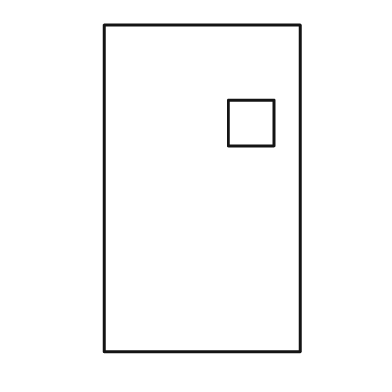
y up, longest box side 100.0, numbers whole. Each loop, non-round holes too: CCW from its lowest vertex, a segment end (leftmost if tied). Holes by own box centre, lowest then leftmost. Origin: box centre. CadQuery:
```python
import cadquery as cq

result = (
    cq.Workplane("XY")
    .moveTo(-30.0, -50.0)
    .lineTo(30.0, -50.0)
    .lineTo(30.0, 50.0)
    .lineTo(-30.0, 50.0)
    .close()
    .moveTo(8.0, 13.0)
    .lineTo(22.0, 13.0)
    .lineTo(22.0, 27.0)
    .lineTo(8.0, 27.0)
    .close()
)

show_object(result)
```